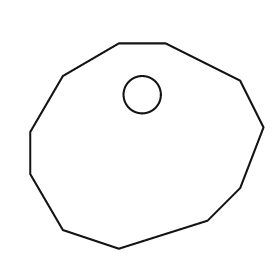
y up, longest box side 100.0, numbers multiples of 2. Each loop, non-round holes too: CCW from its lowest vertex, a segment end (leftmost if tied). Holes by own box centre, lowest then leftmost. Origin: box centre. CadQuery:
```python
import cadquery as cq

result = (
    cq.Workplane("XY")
    .moveTo(-12.0, -44.0)
    .lineTo(26.0, -32.0)
    .lineTo(40.0, -18.0)
    .lineTo(50.0, 8.0)
    .lineTo(40.0, 28.0)
    .lineTo(8.0, 44.0)
    .lineTo(-12.0, 44.0)
    .lineTo(-36.0, 30.0)
    .lineTo(-50.0, 6.0)
    .lineTo(-50.0, -12.0)
    .lineTo(-36.0, -36.0)
    .close()
    .moveTo(-2.0, 22.0)
    .circle(8.0)
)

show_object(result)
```